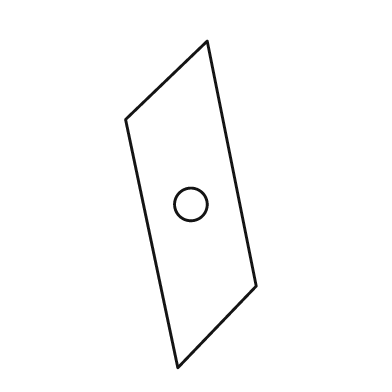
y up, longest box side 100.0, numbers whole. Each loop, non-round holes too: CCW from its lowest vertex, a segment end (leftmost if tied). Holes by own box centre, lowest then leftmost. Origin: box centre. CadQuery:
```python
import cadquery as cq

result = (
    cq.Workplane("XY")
    .moveTo(-4.0, -50.0)
    .lineTo(20.0, -25.0)
    .lineTo(5.0, 50.0)
    .lineTo(-20.0, 26.0)
    .close()
    .moveTo(0.0, 0.0)
    .circle(5.0)
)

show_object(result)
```